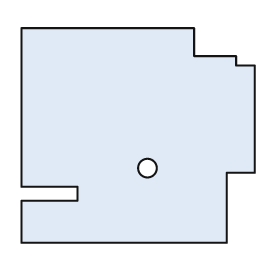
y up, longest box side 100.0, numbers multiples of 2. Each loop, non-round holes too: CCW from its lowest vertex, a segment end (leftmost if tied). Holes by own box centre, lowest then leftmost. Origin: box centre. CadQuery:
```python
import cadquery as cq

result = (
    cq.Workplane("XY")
    .moveTo(-50.0, -46.0)
    .lineTo(38.0, -46.0)
    .lineTo(38.0, -16.0)
    .lineTo(50.0, -16.0)
    .lineTo(50.0, 30.0)
    .lineTo(42.0, 30.0)
    .lineTo(42.0, 34.0)
    .lineTo(24.0, 34.0)
    .lineTo(24.0, 46.0)
    .lineTo(-50.0, 46.0)
    .lineTo(-50.0, -22.0)
    .lineTo(-26.0, -22.0)
    .lineTo(-26.0, -28.0)
    .lineTo(-50.0, -28.0)
    .close()
    .moveTo(4.0, -14.0)
    .circle(4.0)
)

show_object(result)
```